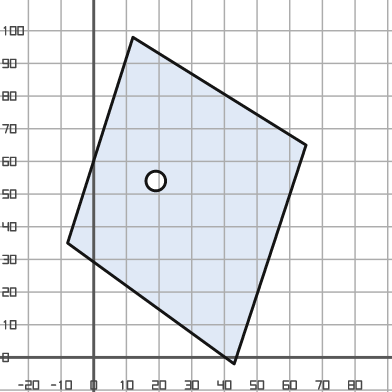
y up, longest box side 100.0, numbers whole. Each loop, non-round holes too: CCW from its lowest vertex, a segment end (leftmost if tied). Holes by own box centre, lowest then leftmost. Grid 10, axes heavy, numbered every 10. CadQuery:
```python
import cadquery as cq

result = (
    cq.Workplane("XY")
    .moveTo(43.0, -2.0)
    .lineTo(65.0, 65.0)
    .lineTo(12.0, 98.0)
    .lineTo(-8.0, 35.0)
    .close()
    .moveTo(19.0, 54.0)
    .circle(3.0)
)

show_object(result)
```